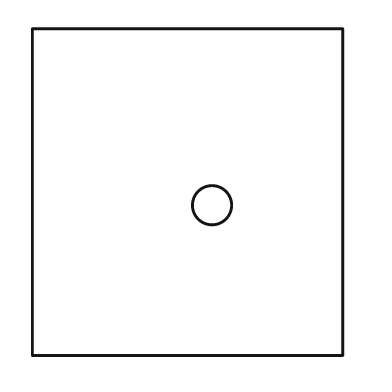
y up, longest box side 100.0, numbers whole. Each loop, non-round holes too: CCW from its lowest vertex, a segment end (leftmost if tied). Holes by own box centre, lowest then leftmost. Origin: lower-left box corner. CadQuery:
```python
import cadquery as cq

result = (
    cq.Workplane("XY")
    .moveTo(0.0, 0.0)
    .lineTo(95.0, 0.0)
    .lineTo(95.0, 100.0)
    .lineTo(0.0, 100.0)
    .close()
    .moveTo(55.0, 46.0)
    .circle(6.0)
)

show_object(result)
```